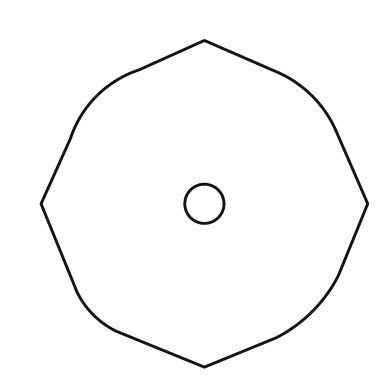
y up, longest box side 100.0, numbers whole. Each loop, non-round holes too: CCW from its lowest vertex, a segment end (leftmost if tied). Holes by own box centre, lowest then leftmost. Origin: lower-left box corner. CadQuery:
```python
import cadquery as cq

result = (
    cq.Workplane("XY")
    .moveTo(50.0, 0.0)
    .lineTo(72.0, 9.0)
    .threePointArc((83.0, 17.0), (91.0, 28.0))
    .lineTo(100.0, 50.0)
    .lineTo(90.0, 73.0)
    .threePointArc((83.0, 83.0), (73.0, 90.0))
    .lineTo(50.0, 100.0)
    .lineTo(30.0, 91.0)
    .threePointArc((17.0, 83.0), (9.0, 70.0))
    .lineTo(0.0, 50.0)
    .lineTo(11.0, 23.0)
    .threePointArc((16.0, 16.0), (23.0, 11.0))
    .close()
    .moveTo(50.0, 50.0)
    .circle(6.0)
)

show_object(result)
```